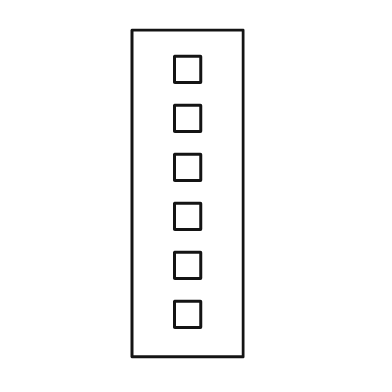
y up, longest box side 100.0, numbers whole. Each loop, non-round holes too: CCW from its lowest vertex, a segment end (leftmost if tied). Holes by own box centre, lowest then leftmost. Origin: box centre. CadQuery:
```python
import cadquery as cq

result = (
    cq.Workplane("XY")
    .moveTo(-17.0, -50.0)
    .lineTo(17.0, -50.0)
    .lineTo(17.0, 50.0)
    .lineTo(-17.0, 50.0)
    .close()
    .moveTo(-4.0, -41.0)
    .lineTo(4.0, -41.0)
    .lineTo(4.0, -33.0)
    .lineTo(-4.0, -33.0)
    .close()
    .moveTo(-4.0, -26.0)
    .lineTo(4.0, -26.0)
    .lineTo(4.0, -18.0)
    .lineTo(-4.0, -18.0)
    .close()
    .moveTo(-4.0, -11.0)
    .lineTo(4.0, -11.0)
    .lineTo(4.0, -3.0)
    .lineTo(-4.0, -3.0)
    .close()
    .moveTo(-4.0, 4.0)
    .lineTo(4.0, 4.0)
    .lineTo(4.0, 12.0)
    .lineTo(-4.0, 12.0)
    .close()
    .moveTo(-4.0, 19.0)
    .lineTo(4.0, 19.0)
    .lineTo(4.0, 27.0)
    .lineTo(-4.0, 27.0)
    .close()
    .moveTo(-4.0, 34.0)
    .lineTo(4.0, 34.0)
    .lineTo(4.0, 42.0)
    .lineTo(-4.0, 42.0)
    .close()
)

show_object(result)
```